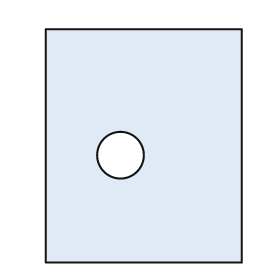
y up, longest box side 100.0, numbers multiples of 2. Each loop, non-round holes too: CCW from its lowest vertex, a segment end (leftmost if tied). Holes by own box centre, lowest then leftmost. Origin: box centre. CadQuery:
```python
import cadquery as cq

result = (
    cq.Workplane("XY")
    .moveTo(-42.0, -50.0)
    .lineTo(42.0, -50.0)
    .lineTo(42.0, 50.0)
    .lineTo(-42.0, 50.0)
    .close()
    .moveTo(-10.0, -4.0)
    .circle(10.0)
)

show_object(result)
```